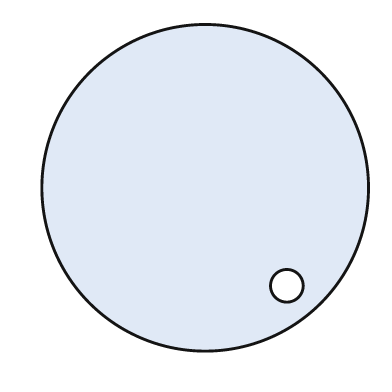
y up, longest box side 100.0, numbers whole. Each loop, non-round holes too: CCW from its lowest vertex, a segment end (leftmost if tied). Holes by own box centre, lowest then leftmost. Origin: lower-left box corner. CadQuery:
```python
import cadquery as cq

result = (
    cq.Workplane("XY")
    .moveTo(50.0, 50.0)
    .circle(50.0)
    .moveTo(75.0, 20.0)
    .circle(5.0)
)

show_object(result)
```